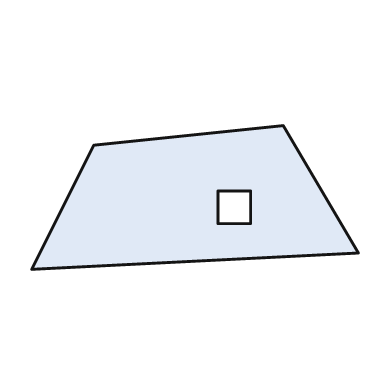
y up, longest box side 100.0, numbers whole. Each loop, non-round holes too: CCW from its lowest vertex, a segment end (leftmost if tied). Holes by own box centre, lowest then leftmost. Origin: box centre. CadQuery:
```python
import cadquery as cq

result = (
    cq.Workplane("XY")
    .moveTo(-50.0, -22.0)
    .lineTo(50.0, -17.0)
    .lineTo(27.0, 22.0)
    .lineTo(-31.0, 16.0)
    .close()
    .moveTo(7.0, -8.0)
    .lineTo(17.0, -8.0)
    .lineTo(17.0, 2.0)
    .lineTo(7.0, 2.0)
    .close()
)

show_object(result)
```